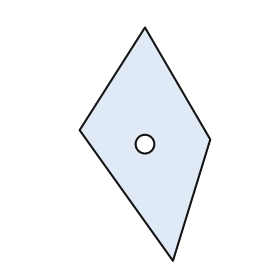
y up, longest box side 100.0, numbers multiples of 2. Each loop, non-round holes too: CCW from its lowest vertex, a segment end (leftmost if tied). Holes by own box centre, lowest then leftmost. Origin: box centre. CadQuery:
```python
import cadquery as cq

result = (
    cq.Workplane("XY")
    .moveTo(12.0, -50.0)
    .lineTo(28.0, 2.0)
    .lineTo(0.0, 50.0)
    .lineTo(-28.0, 6.0)
    .close()
    .moveTo(0.0, 0.0)
    .circle(4.0)
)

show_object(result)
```